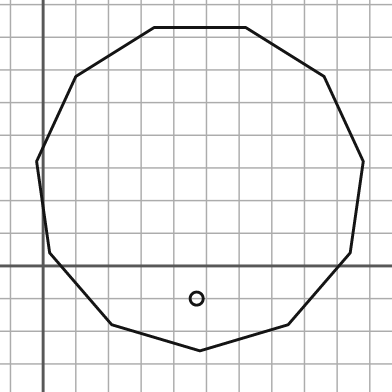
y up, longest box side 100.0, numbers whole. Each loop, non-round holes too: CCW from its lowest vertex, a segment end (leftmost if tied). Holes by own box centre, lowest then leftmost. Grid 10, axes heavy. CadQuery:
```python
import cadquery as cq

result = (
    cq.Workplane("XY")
    .moveTo(48.0, -26.0)
    .lineTo(75.0, -18.0)
    .lineTo(94.0, 4.0)
    .lineTo(98.0, 32.0)
    .lineTo(86.0, 58.0)
    .lineTo(62.0, 73.0)
    .lineTo(34.0, 73.0)
    .lineTo(10.0, 58.0)
    .lineTo(-2.0, 32.0)
    .lineTo(2.0, 4.0)
    .lineTo(21.0, -18.0)
    .close()
    .moveTo(47.0, -10.0)
    .circle(2.0)
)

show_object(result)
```